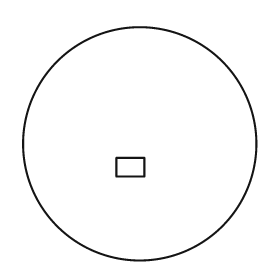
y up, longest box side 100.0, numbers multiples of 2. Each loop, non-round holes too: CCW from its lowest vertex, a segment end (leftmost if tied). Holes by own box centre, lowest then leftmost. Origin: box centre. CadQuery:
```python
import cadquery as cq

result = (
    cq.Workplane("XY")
    .moveTo(0.0, 0.0)
    .circle(50.0)
    .moveTo(-10.0, -14.0)
    .lineTo(2.0, -14.0)
    .lineTo(2.0, -6.0)
    .lineTo(-10.0, -6.0)
    .close()
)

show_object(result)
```